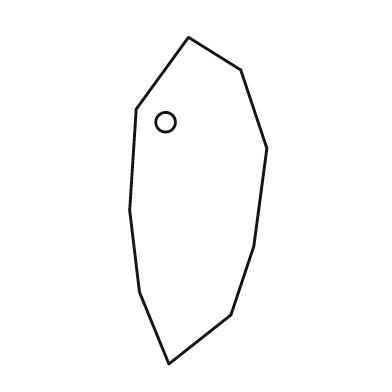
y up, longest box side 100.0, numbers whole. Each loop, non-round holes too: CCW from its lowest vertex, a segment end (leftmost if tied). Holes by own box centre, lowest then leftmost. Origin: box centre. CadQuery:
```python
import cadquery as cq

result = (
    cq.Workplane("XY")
    .moveTo(-9.0, -50.0)
    .lineTo(10.0, -35.0)
    .lineTo(17.0, -14.0)
    .lineTo(21.0, 16.0)
    .lineTo(13.0, 40.0)
    .lineTo(-3.0, 50.0)
    .lineTo(-19.0, 28.0)
    .lineTo(-21.0, -3.0)
    .lineTo(-18.0, -28.0)
    .close()
    .moveTo(-10.0, 24.0)
    .circle(3.0)
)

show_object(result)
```